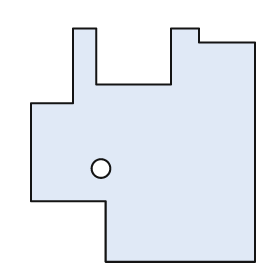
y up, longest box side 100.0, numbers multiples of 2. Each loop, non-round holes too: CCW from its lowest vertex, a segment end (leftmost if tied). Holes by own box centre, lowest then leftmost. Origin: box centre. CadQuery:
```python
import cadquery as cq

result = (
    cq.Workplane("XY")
    .moveTo(-16.0, -50.0)
    .lineTo(48.0, -50.0)
    .lineTo(48.0, 44.0)
    .lineTo(24.0, 44.0)
    .lineTo(24.0, 50.0)
    .lineTo(12.0, 50.0)
    .lineTo(12.0, 26.0)
    .lineTo(-20.0, 26.0)
    .lineTo(-20.0, 50.0)
    .lineTo(-30.0, 50.0)
    .lineTo(-30.0, 18.0)
    .lineTo(-48.0, 18.0)
    .lineTo(-48.0, -24.0)
    .lineTo(-16.0, -24.0)
    .close()
    .moveTo(-18.0, -10.0)
    .circle(4.0)
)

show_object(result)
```